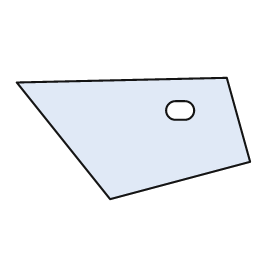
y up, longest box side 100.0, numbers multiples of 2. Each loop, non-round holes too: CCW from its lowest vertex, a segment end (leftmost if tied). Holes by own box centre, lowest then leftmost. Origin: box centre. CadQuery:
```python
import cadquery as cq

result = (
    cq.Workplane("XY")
    .moveTo(-10.0, -26.0)
    .lineTo(50.0, -10.0)
    .lineTo(40.0, 26.0)
    .lineTo(-50.0, 24.0)
    .close()
    .moveTo(18.0, 8.0)
    .lineTo(22.0, 8.0)
    .threePointArc((26.0, 12.0), (22.0, 16.0))
    .lineTo(18.0, 16.0)
    .threePointArc((14.0, 12.0), (18.0, 8.0))
    .close()
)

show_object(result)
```